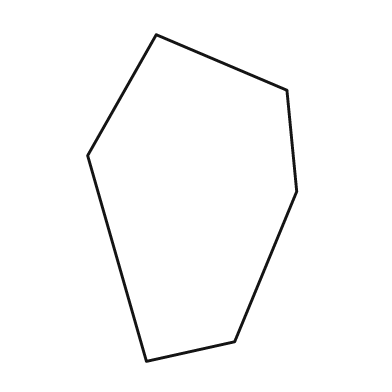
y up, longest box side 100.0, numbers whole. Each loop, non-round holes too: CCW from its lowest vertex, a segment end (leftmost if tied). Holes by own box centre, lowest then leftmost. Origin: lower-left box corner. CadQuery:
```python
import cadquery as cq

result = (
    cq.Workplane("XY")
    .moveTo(18.0, 0.0)
    .lineTo(45.0, 6.0)
    .lineTo(64.0, 52.0)
    .lineTo(61.0, 83.0)
    .lineTo(21.0, 100.0)
    .lineTo(0.0, 63.0)
    .close()
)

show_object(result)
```